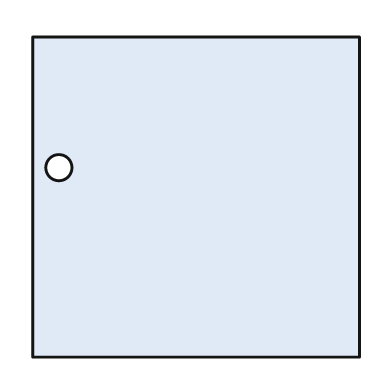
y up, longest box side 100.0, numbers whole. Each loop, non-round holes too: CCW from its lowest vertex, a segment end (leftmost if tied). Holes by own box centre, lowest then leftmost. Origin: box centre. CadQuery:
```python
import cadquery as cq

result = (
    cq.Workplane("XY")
    .moveTo(-50.0, -49.0)
    .lineTo(50.0, -49.0)
    .lineTo(50.0, 49.0)
    .lineTo(-50.0, 49.0)
    .close()
    .moveTo(-42.0, 9.0)
    .circle(4.0)
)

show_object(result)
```